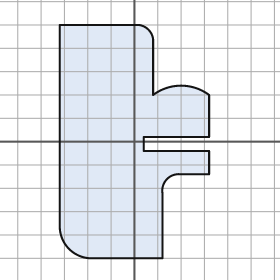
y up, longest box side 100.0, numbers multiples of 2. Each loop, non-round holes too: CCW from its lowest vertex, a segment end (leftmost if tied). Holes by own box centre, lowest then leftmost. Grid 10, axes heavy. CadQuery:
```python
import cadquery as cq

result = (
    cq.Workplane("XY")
    .moveTo(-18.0, -50.0)
    .lineTo(12.0, -50.0)
    .lineTo(12.0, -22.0)
    .threePointArc((14.0, -16.0), (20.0, -14.0))
    .lineTo(32.0, -14.0)
    .lineTo(32.0, -4.0)
    .lineTo(4.0, -4.0)
    .lineTo(4.0, 2.0)
    .lineTo(32.0, 2.0)
    .lineTo(32.0, 20.0)
    .threePointArc((20.0, 24.0), (8.0, 20.0))
    .lineTo(8.0, 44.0)
    .threePointArc((6.0, 48.0), (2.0, 50.0))
    .lineTo(-32.0, 50.0)
    .lineTo(-32.0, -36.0)
    .threePointArc((-28.0, -46.0), (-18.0, -50.0))
    .close()
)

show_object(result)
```